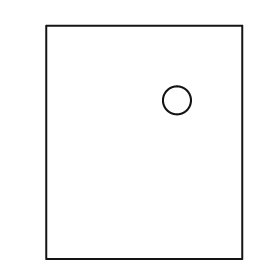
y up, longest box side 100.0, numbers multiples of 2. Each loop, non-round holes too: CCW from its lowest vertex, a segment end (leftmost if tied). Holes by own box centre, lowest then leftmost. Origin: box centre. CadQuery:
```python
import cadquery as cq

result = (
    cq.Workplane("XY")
    .moveTo(-42.0, -50.0)
    .lineTo(42.0, -50.0)
    .lineTo(42.0, 50.0)
    .lineTo(-42.0, 50.0)
    .close()
    .moveTo(14.0, 18.0)
    .circle(6.0)
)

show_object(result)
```